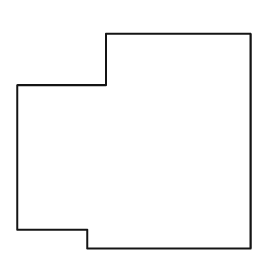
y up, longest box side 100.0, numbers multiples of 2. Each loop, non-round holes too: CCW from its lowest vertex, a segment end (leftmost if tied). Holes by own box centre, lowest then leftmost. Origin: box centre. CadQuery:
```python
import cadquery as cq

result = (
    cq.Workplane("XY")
    .moveTo(-20.0, -46.0)
    .lineTo(50.0, -46.0)
    .lineTo(50.0, 46.0)
    .lineTo(-12.0, 46.0)
    .lineTo(-12.0, 24.0)
    .lineTo(-50.0, 24.0)
    .lineTo(-50.0, -38.0)
    .lineTo(-20.0, -38.0)
    .close()
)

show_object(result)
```